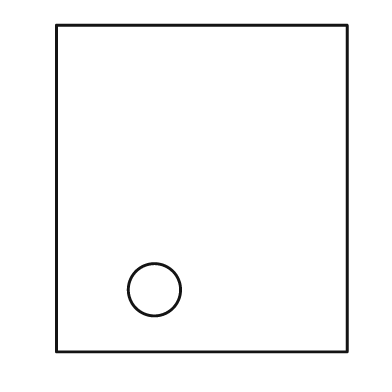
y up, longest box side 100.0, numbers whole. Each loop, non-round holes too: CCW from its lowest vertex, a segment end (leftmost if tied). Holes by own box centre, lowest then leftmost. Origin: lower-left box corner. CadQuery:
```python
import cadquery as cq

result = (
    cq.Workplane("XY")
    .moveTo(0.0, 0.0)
    .lineTo(89.0, 0.0)
    .lineTo(89.0, 100.0)
    .lineTo(0.0, 100.0)
    .close()
    .moveTo(30.0, 19.0)
    .circle(8.0)
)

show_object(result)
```